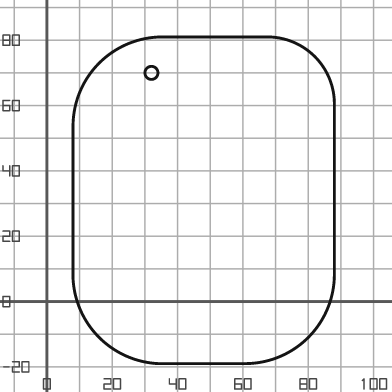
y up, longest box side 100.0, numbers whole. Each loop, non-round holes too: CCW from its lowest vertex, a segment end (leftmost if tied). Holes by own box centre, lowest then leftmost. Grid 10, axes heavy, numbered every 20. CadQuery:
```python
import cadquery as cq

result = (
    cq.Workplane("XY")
    .moveTo(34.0, -19.0)
    .lineTo(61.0, -19.0)
    .threePointArc((80.0, -11.0), (88.0, 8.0))
    .lineTo(88.0, 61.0)
    .threePointArc((82.0, 75.0), (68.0, 81.0))
    .lineTo(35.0, 81.0)
    .threePointArc((16.0, 73.0), (8.0, 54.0))
    .lineTo(8.0, 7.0)
    .threePointArc((16.0, -11.0), (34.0, -19.0))
    .close()
    .moveTo(32.0, 70.0)
    .circle(2.0)
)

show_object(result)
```